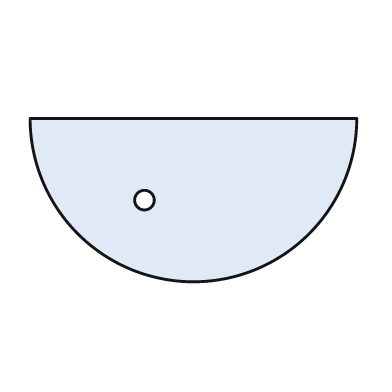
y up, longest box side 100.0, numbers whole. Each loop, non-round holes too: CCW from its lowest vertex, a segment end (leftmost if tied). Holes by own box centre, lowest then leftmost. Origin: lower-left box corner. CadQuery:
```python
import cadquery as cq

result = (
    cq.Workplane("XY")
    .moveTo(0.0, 50.0)
    .threePointArc((50.0, 0.0), (100.0, 50.0))
    .close()
    .moveTo(35.0, 25.0)
    .circle(3.0)
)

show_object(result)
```